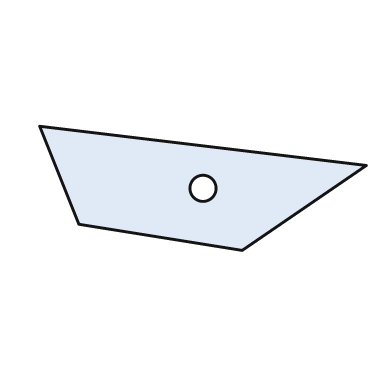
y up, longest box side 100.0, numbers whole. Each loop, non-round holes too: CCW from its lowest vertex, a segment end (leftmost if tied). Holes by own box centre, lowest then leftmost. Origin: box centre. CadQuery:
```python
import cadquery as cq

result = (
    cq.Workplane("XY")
    .moveTo(12.0, -19.0)
    .lineTo(50.0, 7.0)
    .lineTo(-50.0, 19.0)
    .lineTo(-38.0, -11.0)
    .close()
    .moveTo(0.0, 0.0)
    .circle(4.0)
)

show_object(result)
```